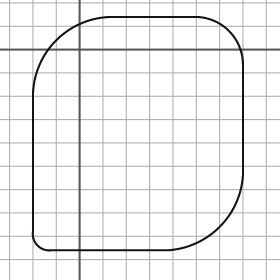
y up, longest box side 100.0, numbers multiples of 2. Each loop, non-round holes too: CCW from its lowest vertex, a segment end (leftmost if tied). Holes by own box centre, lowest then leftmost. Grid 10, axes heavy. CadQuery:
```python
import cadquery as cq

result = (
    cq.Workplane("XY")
    .moveTo(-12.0, -86.0)
    .lineTo(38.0, -86.0)
    .threePointArc((60.0, -76.0), (70.0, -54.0))
    .lineTo(70.0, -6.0)
    .threePointArc((64.0, 8.0), (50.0, 14.0))
    .lineTo(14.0, 14.0)
    .threePointArc((-10.0, 4.0), (-20.0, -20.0))
    .lineTo(-20.0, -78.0)
    .threePointArc((-18.0, -84.0), (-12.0, -86.0))
    .close()
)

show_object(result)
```